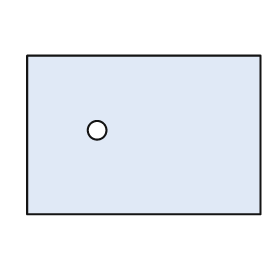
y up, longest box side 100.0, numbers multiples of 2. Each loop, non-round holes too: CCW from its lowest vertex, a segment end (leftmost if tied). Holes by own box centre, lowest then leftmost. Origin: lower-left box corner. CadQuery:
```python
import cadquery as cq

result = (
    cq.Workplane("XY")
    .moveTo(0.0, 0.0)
    .lineTo(100.0, 0.0)
    .lineTo(100.0, 68.0)
    .lineTo(0.0, 68.0)
    .close()
    .moveTo(30.0, 36.0)
    .circle(4.0)
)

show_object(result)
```